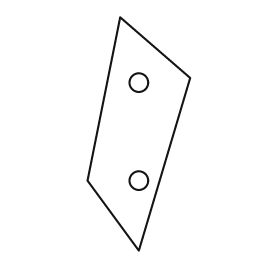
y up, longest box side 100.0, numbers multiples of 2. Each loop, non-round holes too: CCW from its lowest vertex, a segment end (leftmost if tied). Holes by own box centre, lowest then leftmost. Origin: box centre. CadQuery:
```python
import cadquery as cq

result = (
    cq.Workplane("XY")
    .moveTo(0.0, -50.0)
    .lineTo(22.0, 24.0)
    .lineTo(-8.0, 50.0)
    .lineTo(-22.0, -20.0)
    .close()
    .moveTo(0.0, -20.0)
    .circle(4.0)
    .moveTo(0.0, 22.0)
    .circle(4.0)
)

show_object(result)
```